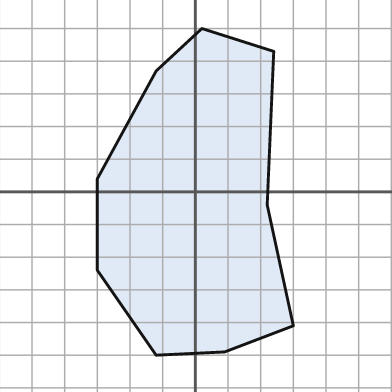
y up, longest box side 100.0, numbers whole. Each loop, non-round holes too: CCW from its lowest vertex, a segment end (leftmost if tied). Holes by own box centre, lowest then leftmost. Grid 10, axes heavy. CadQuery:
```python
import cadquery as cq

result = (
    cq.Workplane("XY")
    .moveTo(-12.0, -50.0)
    .lineTo(9.0, -49.0)
    .lineTo(30.0, -41.0)
    .lineTo(22.0, -4.0)
    .lineTo(24.0, 43.0)
    .lineTo(2.0, 50.0)
    .lineTo(-12.0, 37.0)
    .lineTo(-30.0, 4.0)
    .lineTo(-30.0, -24.0)
    .close()
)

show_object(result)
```